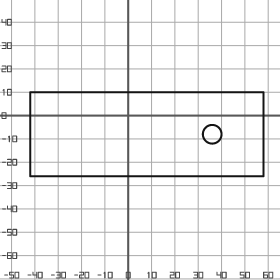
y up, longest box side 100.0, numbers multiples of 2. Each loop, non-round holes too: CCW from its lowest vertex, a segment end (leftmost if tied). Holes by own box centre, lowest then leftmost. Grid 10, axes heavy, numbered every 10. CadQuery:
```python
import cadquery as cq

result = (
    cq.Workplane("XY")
    .moveTo(-42.0, -26.0)
    .lineTo(58.0, -26.0)
    .lineTo(58.0, 10.0)
    .lineTo(-42.0, 10.0)
    .close()
    .moveTo(36.0, -8.0)
    .circle(4.0)
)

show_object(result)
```